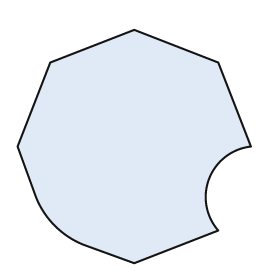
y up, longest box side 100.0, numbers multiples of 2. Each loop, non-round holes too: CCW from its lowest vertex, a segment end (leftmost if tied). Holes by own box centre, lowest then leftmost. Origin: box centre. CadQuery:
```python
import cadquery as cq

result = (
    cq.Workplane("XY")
    .moveTo(0.0, -50.0)
    .lineTo(36.0, -36.0)
    .threePointArc((32.0, -14.0), (50.0, 0.0))
    .lineTo(36.0, 36.0)
    .lineTo(0.0, 50.0)
    .lineTo(-36.0, 36.0)
    .lineTo(-50.0, 0.0)
    .lineTo(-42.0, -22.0)
    .threePointArc((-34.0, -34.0), (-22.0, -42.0))
    .close()
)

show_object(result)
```